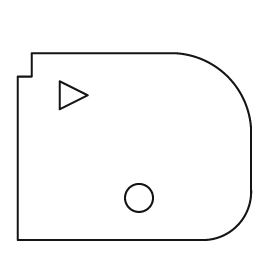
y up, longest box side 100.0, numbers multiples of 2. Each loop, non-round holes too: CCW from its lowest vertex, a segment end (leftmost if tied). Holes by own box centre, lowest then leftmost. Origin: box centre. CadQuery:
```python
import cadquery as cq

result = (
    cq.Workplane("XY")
    .moveTo(-50.0, -40.0)
    .lineTo(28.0, -40.0)
    .threePointArc((44.0, -34.0), (50.0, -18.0))
    .lineTo(50.0, 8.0)
    .threePointArc((40.0, 30.0), (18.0, 40.0))
    .lineTo(-44.0, 40.0)
    .lineTo(-44.0, 30.0)
    .lineTo(-50.0, 30.0)
    .close()
    .moveTo(2.0, -22.0)
    .circle(6.0)
    .moveTo(-32.0, 16.0)
    .lineTo(-20.0, 22.0)
    .lineTo(-32.0, 28.0)
    .close()
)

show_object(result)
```